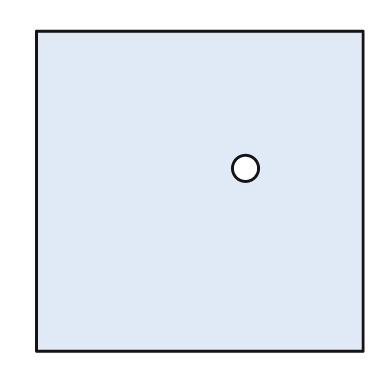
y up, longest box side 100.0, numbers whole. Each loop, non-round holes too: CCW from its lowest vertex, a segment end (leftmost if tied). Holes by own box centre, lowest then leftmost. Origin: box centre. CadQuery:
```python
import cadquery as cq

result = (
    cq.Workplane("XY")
    .moveTo(-50.0, -49.0)
    .lineTo(50.0, -49.0)
    .lineTo(50.0, 49.0)
    .lineTo(-50.0, 49.0)
    .close()
    .moveTo(14.0, 7.0)
    .circle(4.0)
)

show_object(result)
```